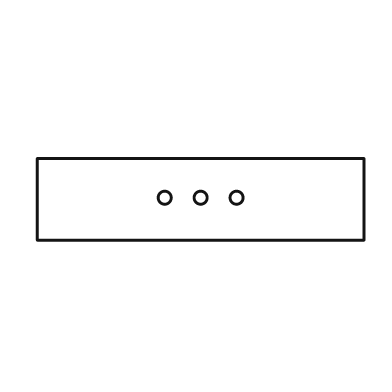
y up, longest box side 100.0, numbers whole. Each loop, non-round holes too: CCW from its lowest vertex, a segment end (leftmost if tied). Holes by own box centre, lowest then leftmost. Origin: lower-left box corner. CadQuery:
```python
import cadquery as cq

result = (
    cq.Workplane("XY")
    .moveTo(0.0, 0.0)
    .lineTo(100.0, 0.0)
    .lineTo(100.0, 25.0)
    .lineTo(0.0, 25.0)
    .close()
    .moveTo(39.0, 13.0)
    .circle(2.0)
    .moveTo(50.0, 13.0)
    .circle(2.0)
    .moveTo(61.0, 13.0)
    .circle(2.0)
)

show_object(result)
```